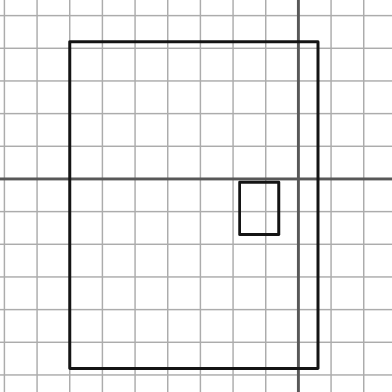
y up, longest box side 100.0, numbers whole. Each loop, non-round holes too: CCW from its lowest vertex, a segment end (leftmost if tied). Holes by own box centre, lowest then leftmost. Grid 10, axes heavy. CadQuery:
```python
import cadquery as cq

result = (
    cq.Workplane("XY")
    .moveTo(-70.0, -58.0)
    .lineTo(6.0, -58.0)
    .lineTo(6.0, 42.0)
    .lineTo(-70.0, 42.0)
    .close()
    .moveTo(-18.0, -17.0)
    .lineTo(-6.0, -17.0)
    .lineTo(-6.0, -1.0)
    .lineTo(-18.0, -1.0)
    .close()
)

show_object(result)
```